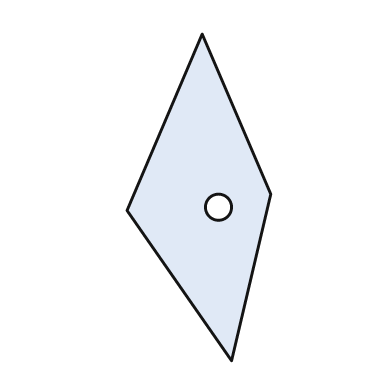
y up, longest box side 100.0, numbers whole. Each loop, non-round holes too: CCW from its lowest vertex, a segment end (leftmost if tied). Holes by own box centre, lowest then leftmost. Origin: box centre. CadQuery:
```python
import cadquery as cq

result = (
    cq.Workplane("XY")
    .moveTo(10.0, -50.0)
    .lineTo(22.0, 1.0)
    .lineTo(1.0, 50.0)
    .lineTo(-22.0, -4.0)
    .close()
    .moveTo(6.0, -3.0)
    .circle(4.0)
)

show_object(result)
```